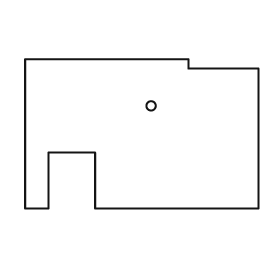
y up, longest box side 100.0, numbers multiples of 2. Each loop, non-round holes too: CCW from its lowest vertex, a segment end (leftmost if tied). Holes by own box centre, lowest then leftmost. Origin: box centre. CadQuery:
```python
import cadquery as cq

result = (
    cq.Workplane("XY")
    .moveTo(-50.0, -32.0)
    .lineTo(-40.0, -32.0)
    .lineTo(-40.0, -8.0)
    .lineTo(-20.0, -8.0)
    .lineTo(-20.0, -32.0)
    .lineTo(50.0, -32.0)
    .lineTo(50.0, 28.0)
    .lineTo(20.0, 28.0)
    .lineTo(20.0, 32.0)
    .lineTo(-50.0, 32.0)
    .close()
    .moveTo(4.0, 12.0)
    .circle(2.0)
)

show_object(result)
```